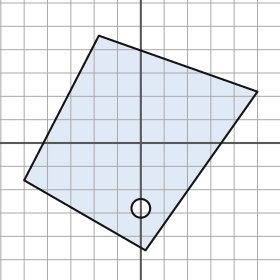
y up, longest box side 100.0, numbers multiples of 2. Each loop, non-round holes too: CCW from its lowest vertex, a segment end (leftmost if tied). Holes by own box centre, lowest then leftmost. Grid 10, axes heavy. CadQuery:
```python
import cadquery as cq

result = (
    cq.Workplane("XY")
    .moveTo(2.0, -46.0)
    .lineTo(50.0, 22.0)
    .lineTo(-18.0, 46.0)
    .lineTo(-50.0, -16.0)
    .close()
    .moveTo(0.0, -28.0)
    .circle(4.0)
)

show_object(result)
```